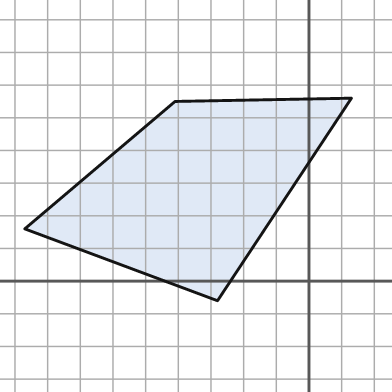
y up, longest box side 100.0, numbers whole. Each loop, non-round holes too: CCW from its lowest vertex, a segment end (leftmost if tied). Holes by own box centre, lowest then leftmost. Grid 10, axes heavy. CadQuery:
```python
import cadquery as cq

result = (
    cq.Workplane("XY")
    .moveTo(-28.0, -6.0)
    .lineTo(13.0, 56.0)
    .lineTo(-41.0, 55.0)
    .lineTo(-87.0, 16.0)
    .close()
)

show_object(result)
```